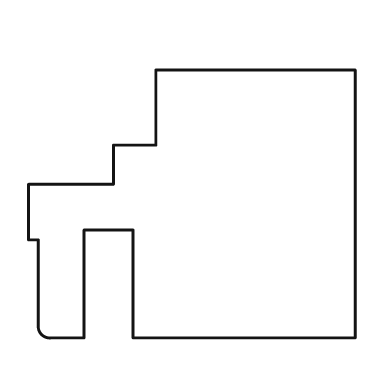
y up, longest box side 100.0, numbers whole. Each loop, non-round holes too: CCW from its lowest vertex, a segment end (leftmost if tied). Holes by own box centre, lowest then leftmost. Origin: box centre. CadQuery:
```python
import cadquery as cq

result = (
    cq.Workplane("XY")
    .moveTo(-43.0, -41.0)
    .lineTo(-33.0, -41.0)
    .lineTo(-33.0, -8.0)
    .lineTo(-18.0, -8.0)
    .lineTo(-18.0, -41.0)
    .lineTo(50.0, -41.0)
    .lineTo(50.0, 41.0)
    .lineTo(-11.0, 41.0)
    .lineTo(-11.0, 18.0)
    .lineTo(-24.0, 18.0)
    .lineTo(-24.0, 6.0)
    .lineTo(-50.0, 6.0)
    .lineTo(-50.0, -11.0)
    .lineTo(-47.0, -11.0)
    .lineTo(-47.0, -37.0)
    .threePointArc((-46.0, -40.0), (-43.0, -41.0))
    .close()
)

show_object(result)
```